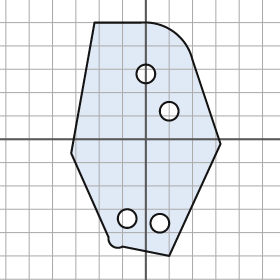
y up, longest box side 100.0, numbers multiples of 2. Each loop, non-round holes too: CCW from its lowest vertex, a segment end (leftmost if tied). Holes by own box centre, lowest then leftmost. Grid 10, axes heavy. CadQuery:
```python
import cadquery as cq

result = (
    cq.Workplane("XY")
    .moveTo(10.0, -50.0)
    .lineTo(32.0, -2.0)
    .lineTo(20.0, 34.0)
    .threePointArc((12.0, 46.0), (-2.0, 50.0))
    .lineTo(-22.0, 50.0)
    .lineTo(-32.0, -6.0)
    .lineTo(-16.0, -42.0)
    .threePointArc((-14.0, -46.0), (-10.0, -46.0))
    .close()
    .moveTo(6.0, -36.0)
    .circle(4.0)
    .moveTo(-8.0, -34.0)
    .circle(4.0)
    .moveTo(10.0, 12.0)
    .circle(4.0)
    .moveTo(0.0, 28.0)
    .circle(4.0)
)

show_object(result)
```